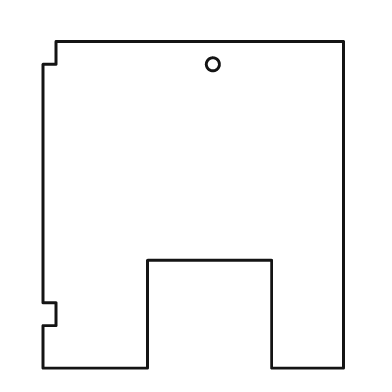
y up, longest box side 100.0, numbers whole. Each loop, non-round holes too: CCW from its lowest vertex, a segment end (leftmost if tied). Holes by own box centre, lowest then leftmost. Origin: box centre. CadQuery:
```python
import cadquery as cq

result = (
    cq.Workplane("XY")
    .moveTo(-46.0, -50.0)
    .lineTo(-14.0, -50.0)
    .lineTo(-14.0, -17.0)
    .lineTo(24.0, -17.0)
    .lineTo(24.0, -50.0)
    .lineTo(46.0, -50.0)
    .lineTo(46.0, 50.0)
    .lineTo(-42.0, 50.0)
    .lineTo(-42.0, 43.0)
    .lineTo(-46.0, 43.0)
    .lineTo(-46.0, -30.0)
    .lineTo(-42.0, -30.0)
    .lineTo(-42.0, -37.0)
    .lineTo(-46.0, -37.0)
    .close()
    .moveTo(6.0, 43.0)
    .circle(2.0)
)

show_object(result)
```